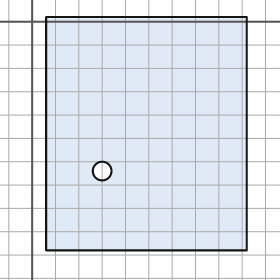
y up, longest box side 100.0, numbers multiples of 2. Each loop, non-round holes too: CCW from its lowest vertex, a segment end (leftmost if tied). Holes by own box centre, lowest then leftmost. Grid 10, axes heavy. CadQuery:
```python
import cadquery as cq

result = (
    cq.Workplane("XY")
    .moveTo(6.0, -98.0)
    .lineTo(92.0, -98.0)
    .lineTo(92.0, 2.0)
    .lineTo(6.0, 2.0)
    .close()
    .moveTo(30.0, -64.0)
    .circle(4.0)
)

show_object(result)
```